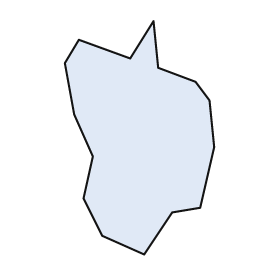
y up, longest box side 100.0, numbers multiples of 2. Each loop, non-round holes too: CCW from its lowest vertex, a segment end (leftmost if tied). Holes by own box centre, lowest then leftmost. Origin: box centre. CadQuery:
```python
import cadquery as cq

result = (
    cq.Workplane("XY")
    .moveTo(2.0, -50.0)
    .lineTo(14.0, -32.0)
    .lineTo(26.0, -30.0)
    .lineTo(32.0, -4.0)
    .lineTo(30.0, 16.0)
    .lineTo(24.0, 24.0)
    .lineTo(8.0, 30.0)
    .lineTo(6.0, 50.0)
    .lineTo(-4.0, 34.0)
    .lineTo(-26.0, 42.0)
    .lineTo(-32.0, 32.0)
    .lineTo(-28.0, 10.0)
    .lineTo(-20.0, -8.0)
    .lineTo(-24.0, -26.0)
    .lineTo(-16.0, -42.0)
    .close()
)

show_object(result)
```